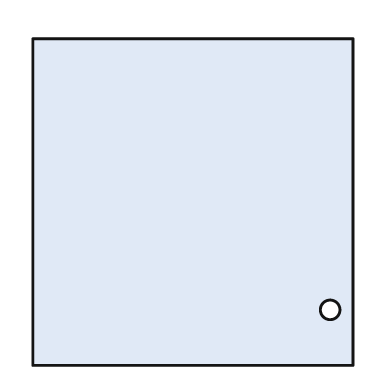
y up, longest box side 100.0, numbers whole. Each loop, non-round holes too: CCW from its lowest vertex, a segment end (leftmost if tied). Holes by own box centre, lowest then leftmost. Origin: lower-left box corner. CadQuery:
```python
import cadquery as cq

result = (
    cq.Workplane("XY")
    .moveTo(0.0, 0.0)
    .lineTo(98.0, 0.0)
    .lineTo(98.0, 100.0)
    .lineTo(0.0, 100.0)
    .close()
    .moveTo(91.0, 17.0)
    .circle(3.0)
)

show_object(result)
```